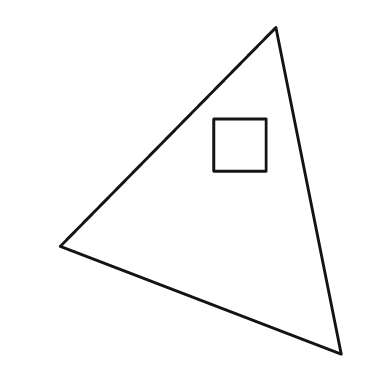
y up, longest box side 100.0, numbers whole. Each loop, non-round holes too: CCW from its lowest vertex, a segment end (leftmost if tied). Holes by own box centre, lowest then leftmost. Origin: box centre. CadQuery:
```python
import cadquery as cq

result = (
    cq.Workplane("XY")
    .moveTo(43.0, -50.0)
    .lineTo(23.0, 50.0)
    .lineTo(-43.0, -17.0)
    .close()
    .moveTo(4.0, 6.0)
    .lineTo(20.0, 6.0)
    .lineTo(20.0, 22.0)
    .lineTo(4.0, 22.0)
    .close()
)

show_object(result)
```